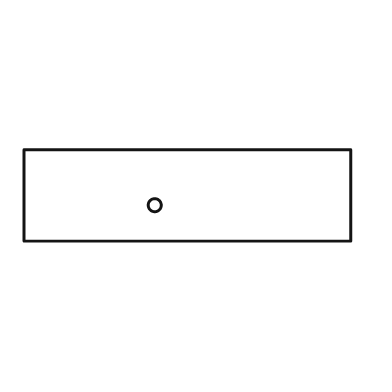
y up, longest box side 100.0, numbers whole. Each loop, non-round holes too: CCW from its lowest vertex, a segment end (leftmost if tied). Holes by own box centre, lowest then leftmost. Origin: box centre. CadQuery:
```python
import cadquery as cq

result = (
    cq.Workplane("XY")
    .moveTo(-50.0, -14.0)
    .lineTo(50.0, -14.0)
    .lineTo(50.0, 14.0)
    .lineTo(-50.0, 14.0)
    .close()
    .moveTo(-10.0, -3.0)
    .circle(2.0)
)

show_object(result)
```